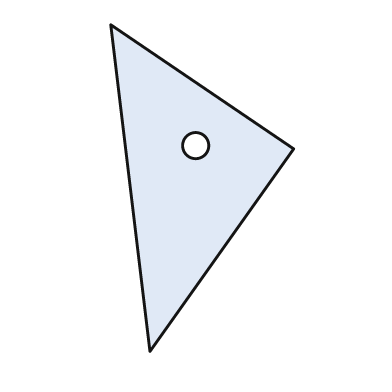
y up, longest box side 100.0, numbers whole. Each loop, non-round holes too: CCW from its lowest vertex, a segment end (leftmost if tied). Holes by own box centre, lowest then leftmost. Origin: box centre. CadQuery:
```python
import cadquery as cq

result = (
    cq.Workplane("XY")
    .moveTo(-16.0, -50.0)
    .lineTo(28.0, 12.0)
    .lineTo(-28.0, 50.0)
    .close()
    .moveTo(-2.0, 13.0)
    .circle(4.0)
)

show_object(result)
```